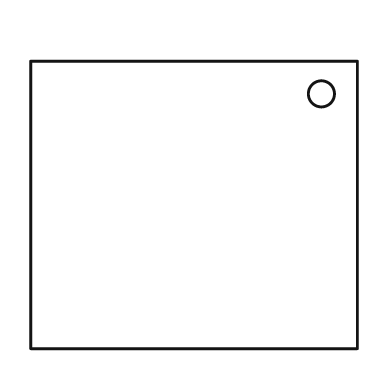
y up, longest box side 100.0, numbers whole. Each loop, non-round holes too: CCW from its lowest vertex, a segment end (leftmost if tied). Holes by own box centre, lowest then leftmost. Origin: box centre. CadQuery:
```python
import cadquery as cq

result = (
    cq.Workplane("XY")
    .moveTo(-50.0, -44.0)
    .lineTo(50.0, -44.0)
    .lineTo(50.0, 44.0)
    .lineTo(-50.0, 44.0)
    .close()
    .moveTo(39.0, 34.0)
    .circle(4.0)
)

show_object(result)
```